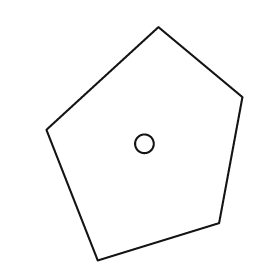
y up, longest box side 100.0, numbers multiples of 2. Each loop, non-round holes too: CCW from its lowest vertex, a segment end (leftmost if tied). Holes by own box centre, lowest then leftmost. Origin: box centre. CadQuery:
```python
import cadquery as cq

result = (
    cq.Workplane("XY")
    .moveTo(-20.0, -50.0)
    .lineTo(32.0, -34.0)
    .lineTo(42.0, 20.0)
    .lineTo(6.0, 50.0)
    .lineTo(-42.0, 6.0)
    .close()
    .moveTo(0.0, 0.0)
    .circle(4.0)
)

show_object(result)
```